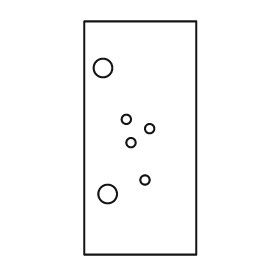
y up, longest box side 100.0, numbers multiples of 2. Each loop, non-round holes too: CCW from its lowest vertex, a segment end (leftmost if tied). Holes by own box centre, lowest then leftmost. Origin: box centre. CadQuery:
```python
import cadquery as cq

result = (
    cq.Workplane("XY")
    .moveTo(-24.0, -50.0)
    .lineTo(24.0, -50.0)
    .lineTo(24.0, 50.0)
    .lineTo(-24.0, 50.0)
    .close()
    .moveTo(-14.0, -24.0)
    .circle(4.0)
    .moveTo(2.0, -18.0)
    .circle(2.0)
    .moveTo(-4.0, -2.0)
    .circle(2.0)
    .moveTo(4.0, 4.0)
    .circle(2.0)
    .moveTo(-6.0, 8.0)
    .circle(2.0)
    .moveTo(-16.0, 30.0)
    .circle(4.0)
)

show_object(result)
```